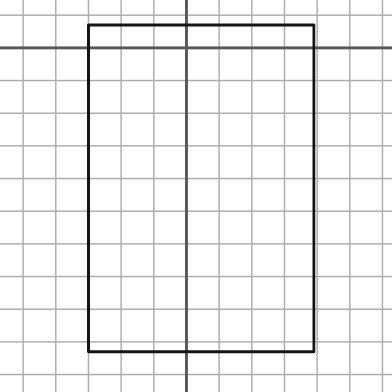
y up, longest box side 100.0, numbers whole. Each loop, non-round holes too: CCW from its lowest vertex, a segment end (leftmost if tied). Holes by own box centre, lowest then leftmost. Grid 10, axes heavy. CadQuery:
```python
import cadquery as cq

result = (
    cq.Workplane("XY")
    .moveTo(-30.0, -93.0)
    .lineTo(39.0, -93.0)
    .lineTo(39.0, 7.0)
    .lineTo(-30.0, 7.0)
    .close()
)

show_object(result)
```